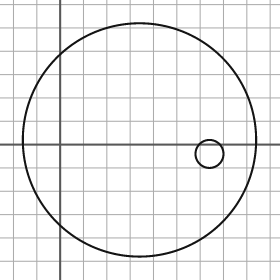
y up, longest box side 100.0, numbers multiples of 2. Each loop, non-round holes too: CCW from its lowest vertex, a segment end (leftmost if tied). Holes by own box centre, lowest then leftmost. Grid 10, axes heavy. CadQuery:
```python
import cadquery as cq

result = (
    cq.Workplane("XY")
    .moveTo(34.0, 2.0)
    .circle(50.0)
    .moveTo(64.0, -4.0)
    .circle(6.0)
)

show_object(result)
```